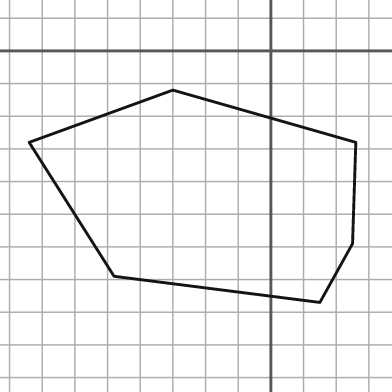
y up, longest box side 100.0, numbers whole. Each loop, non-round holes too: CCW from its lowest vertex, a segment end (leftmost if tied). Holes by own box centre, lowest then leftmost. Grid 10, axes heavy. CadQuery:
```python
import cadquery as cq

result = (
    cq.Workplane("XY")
    .moveTo(15.0, -77.0)
    .lineTo(25.0, -59.0)
    .lineTo(26.0, -28.0)
    .lineTo(-30.0, -12.0)
    .lineTo(-74.0, -28.0)
    .lineTo(-48.0, -69.0)
    .close()
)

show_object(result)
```